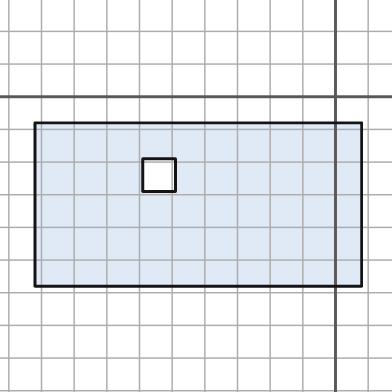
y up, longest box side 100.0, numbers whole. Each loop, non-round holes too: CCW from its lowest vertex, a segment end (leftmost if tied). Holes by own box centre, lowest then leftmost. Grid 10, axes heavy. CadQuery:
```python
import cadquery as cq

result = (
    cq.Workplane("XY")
    .moveTo(-92.0, -58.0)
    .lineTo(8.0, -58.0)
    .lineTo(8.0, -8.0)
    .lineTo(-92.0, -8.0)
    .close()
    .moveTo(-59.0, -29.0)
    .lineTo(-49.0, -29.0)
    .lineTo(-49.0, -19.0)
    .lineTo(-59.0, -19.0)
    .close()
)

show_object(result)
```